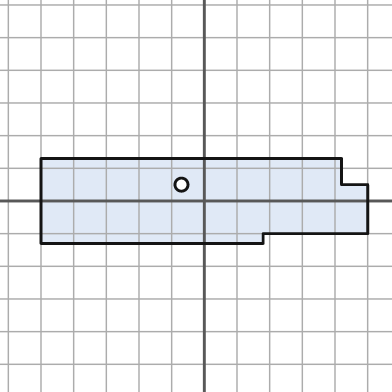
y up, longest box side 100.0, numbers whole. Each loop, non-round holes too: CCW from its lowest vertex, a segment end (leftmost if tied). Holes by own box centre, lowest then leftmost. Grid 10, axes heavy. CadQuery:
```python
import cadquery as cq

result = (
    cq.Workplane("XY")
    .moveTo(-50.0, -13.0)
    .lineTo(18.0, -13.0)
    .lineTo(18.0, -10.0)
    .lineTo(50.0, -10.0)
    .lineTo(50.0, 5.0)
    .lineTo(42.0, 5.0)
    .lineTo(42.0, 13.0)
    .lineTo(-50.0, 13.0)
    .close()
    .moveTo(-7.0, 5.0)
    .circle(2.0)
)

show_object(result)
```